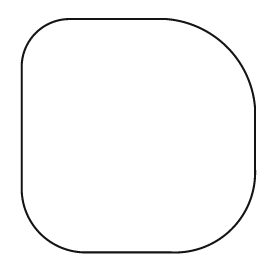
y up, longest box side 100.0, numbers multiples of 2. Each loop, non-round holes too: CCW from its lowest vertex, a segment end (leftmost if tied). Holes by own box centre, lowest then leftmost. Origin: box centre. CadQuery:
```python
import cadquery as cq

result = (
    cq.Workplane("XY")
    .moveTo(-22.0, -50.0)
    .lineTo(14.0, -50.0)
    .threePointArc((40.0, -40.0), (50.0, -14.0))
    .lineTo(50.0, 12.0)
    .threePointArc((38.0, 38.0), (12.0, 50.0))
    .lineTo(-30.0, 50.0)
    .threePointArc((-44.0, 44.0), (-50.0, 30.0))
    .lineTo(-50.0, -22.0)
    .threePointArc((-42.0, -42.0), (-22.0, -50.0))
    .close()
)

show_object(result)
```